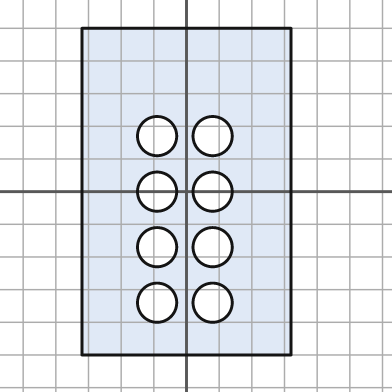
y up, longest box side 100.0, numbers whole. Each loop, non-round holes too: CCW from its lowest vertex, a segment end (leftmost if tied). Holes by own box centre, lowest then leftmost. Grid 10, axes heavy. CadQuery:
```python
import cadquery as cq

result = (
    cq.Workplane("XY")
    .moveTo(-32.0, -50.0)
    .lineTo(32.0, -50.0)
    .lineTo(32.0, 50.0)
    .lineTo(-32.0, 50.0)
    .close()
    .moveTo(-9.0, -34.0)
    .circle(6.0)
    .moveTo(8.0, -34.0)
    .circle(6.0)
    .moveTo(-9.0, -17.0)
    .circle(6.0)
    .moveTo(8.0, -17.0)
    .circle(6.0)
    .moveTo(-9.0, 0.0)
    .circle(6.0)
    .moveTo(8.0, 0.0)
    .circle(6.0)
    .moveTo(-9.0, 17.0)
    .circle(6.0)
    .moveTo(8.0, 17.0)
    .circle(6.0)
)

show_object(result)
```